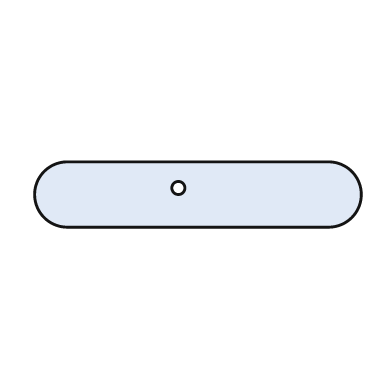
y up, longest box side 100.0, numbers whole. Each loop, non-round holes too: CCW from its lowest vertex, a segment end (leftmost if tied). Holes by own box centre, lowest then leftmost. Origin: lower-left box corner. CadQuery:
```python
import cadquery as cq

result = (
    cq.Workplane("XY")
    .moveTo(10.0, 0.0)
    .lineTo(90.0, 0.0)
    .threePointArc((100.0, 10.0), (90.0, 20.0))
    .lineTo(10.0, 20.0)
    .threePointArc((0.0, 10.0), (10.0, 0.0))
    .close()
    .moveTo(44.0, 12.0)
    .circle(2.0)
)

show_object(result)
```